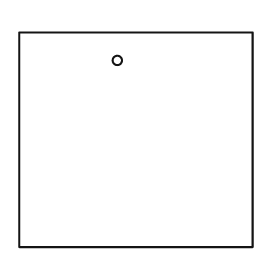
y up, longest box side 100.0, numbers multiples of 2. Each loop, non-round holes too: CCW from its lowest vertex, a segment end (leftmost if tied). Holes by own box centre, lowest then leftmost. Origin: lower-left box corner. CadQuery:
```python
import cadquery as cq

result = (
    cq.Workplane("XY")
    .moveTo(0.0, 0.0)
    .lineTo(100.0, 0.0)
    .lineTo(100.0, 92.0)
    .lineTo(0.0, 92.0)
    .close()
    .moveTo(42.0, 80.0)
    .circle(2.0)
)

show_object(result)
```